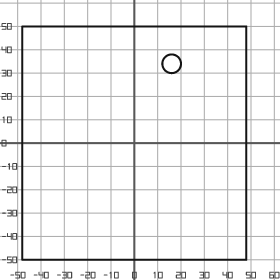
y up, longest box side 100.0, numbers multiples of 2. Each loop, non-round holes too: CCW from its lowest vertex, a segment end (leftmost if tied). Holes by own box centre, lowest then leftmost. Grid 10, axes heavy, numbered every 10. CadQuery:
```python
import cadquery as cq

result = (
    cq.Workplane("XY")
    .moveTo(-48.0, -50.0)
    .lineTo(48.0, -50.0)
    .lineTo(48.0, 50.0)
    .lineTo(-48.0, 50.0)
    .close()
    .moveTo(16.0, 34.0)
    .circle(4.0)
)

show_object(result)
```